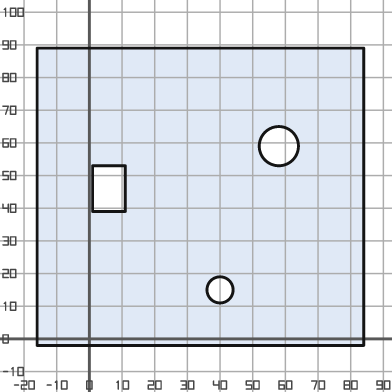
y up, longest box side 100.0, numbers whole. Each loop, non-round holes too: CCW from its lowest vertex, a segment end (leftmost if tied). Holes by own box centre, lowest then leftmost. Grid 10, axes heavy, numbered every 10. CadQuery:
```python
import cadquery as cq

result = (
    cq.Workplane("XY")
    .moveTo(-16.0, -2.0)
    .lineTo(84.0, -2.0)
    .lineTo(84.0, 89.0)
    .lineTo(-16.0, 89.0)
    .close()
    .moveTo(40.0, 15.0)
    .circle(4.0)
    .moveTo(1.0, 39.0)
    .lineTo(11.0, 39.0)
    .lineTo(11.0, 53.0)
    .lineTo(1.0, 53.0)
    .close()
    .moveTo(58.0, 59.0)
    .circle(6.0)
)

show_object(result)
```